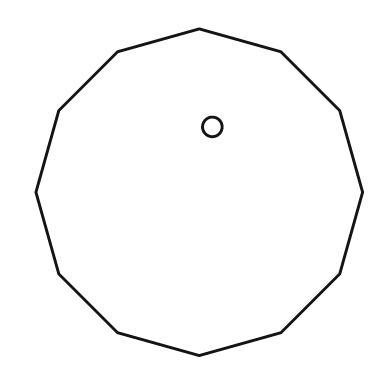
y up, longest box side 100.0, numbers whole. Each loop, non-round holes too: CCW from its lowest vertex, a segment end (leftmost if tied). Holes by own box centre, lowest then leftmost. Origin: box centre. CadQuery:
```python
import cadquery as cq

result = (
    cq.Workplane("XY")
    .moveTo(0.0, -50.0)
    .lineTo(25.0, -43.0)
    .lineTo(43.0, -25.0)
    .lineTo(50.0, 0.0)
    .lineTo(43.0, 25.0)
    .lineTo(25.0, 43.0)
    .lineTo(0.0, 50.0)
    .lineTo(-25.0, 43.0)
    .lineTo(-43.0, 25.0)
    .lineTo(-50.0, 0.0)
    .lineTo(-43.0, -25.0)
    .lineTo(-25.0, -43.0)
    .close()
    .moveTo(4.0, 20.0)
    .circle(3.0)
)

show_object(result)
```